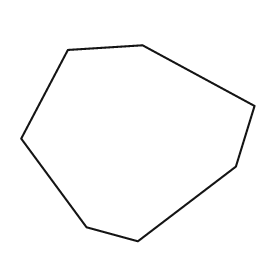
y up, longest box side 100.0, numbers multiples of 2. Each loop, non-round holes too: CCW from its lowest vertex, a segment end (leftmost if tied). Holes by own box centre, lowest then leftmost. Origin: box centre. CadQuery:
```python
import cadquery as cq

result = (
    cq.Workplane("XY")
    .moveTo(0.0, -42.0)
    .lineTo(42.0, -10.0)
    .lineTo(50.0, 16.0)
    .lineTo(2.0, 42.0)
    .lineTo(-30.0, 40.0)
    .lineTo(-50.0, 2.0)
    .lineTo(-22.0, -36.0)
    .close()
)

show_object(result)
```